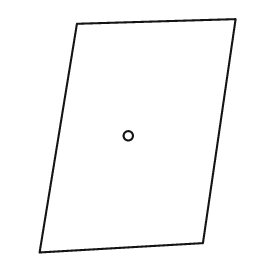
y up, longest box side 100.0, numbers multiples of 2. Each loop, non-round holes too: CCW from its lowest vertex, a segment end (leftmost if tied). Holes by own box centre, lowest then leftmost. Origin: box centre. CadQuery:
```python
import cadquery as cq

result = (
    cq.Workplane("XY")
    .moveTo(-42.0, -50.0)
    .lineTo(28.0, -46.0)
    .lineTo(42.0, 50.0)
    .lineTo(-26.0, 48.0)
    .close()
    .moveTo(-4.0, 0.0)
    .circle(2.0)
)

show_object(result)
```